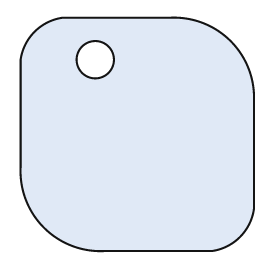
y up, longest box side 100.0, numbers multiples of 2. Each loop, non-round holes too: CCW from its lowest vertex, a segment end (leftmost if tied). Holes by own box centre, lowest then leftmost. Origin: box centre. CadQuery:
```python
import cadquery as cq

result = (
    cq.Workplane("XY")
    .moveTo(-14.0, -50.0)
    .lineTo(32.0, -50.0)
    .threePointArc((44.0, -44.0), (50.0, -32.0))
    .lineTo(50.0, 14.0)
    .threePointArc((40.0, 40.0), (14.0, 50.0))
    .lineTo(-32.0, 50.0)
    .threePointArc((-44.0, 44.0), (-50.0, 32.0))
    .lineTo(-50.0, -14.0)
    .threePointArc((-40.0, -40.0), (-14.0, -50.0))
    .close()
    .moveTo(-18.0, 32.0)
    .circle(8.0)
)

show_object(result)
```